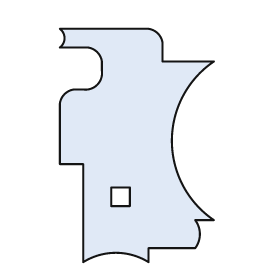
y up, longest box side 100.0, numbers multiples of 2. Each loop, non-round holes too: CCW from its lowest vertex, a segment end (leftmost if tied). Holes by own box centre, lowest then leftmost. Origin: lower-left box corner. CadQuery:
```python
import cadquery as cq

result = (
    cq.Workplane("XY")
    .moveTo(10.0, 0.0)
    .threePointArc((24.0, 4.0), (38.0, 0.0))
    .lineTo(38.0, 6.0)
    .lineTo(58.0, 6.0)
    .threePointArc((60.0, 12.0), (58.0, 18.0))
    .lineTo(66.0, 18.0)
    .threePointArc((48.0, 52.0), (66.0, 86.0))
    .lineTo(44.0, 86.0)
    .lineTo(44.0, 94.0)
    .threePointArc((42.0, 98.0), (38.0, 100.0))
    .lineTo(0.0, 100.0)
    .threePointArc((2.0, 96.0), (0.0, 92.0))
    .lineTo(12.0, 92.0)
    .threePointArc((16.0, 90.0), (18.0, 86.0))
    .lineTo(18.0, 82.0)
    .threePointArc((16.0, 76.0), (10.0, 74.0))
    .lineTo(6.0, 74.0)
    .threePointArc((2.0, 72.0), (0.0, 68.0))
    .lineTo(0.0, 42.0)
    .lineTo(10.0, 42.0)
    .close()
    .moveTo(22.0, 24.0)
    .lineTo(30.0, 24.0)
    .lineTo(30.0, 32.0)
    .lineTo(22.0, 32.0)
    .close()
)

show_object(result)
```